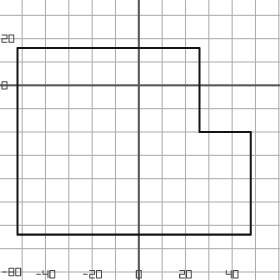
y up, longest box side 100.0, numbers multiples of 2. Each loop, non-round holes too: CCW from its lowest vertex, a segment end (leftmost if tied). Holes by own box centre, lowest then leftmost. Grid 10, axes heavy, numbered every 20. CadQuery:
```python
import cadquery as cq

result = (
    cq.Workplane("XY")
    .moveTo(-52.0, -64.0)
    .lineTo(48.0, -64.0)
    .lineTo(48.0, -20.0)
    .lineTo(26.0, -20.0)
    .lineTo(26.0, 16.0)
    .lineTo(-52.0, 16.0)
    .close()
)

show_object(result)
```